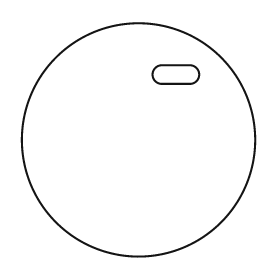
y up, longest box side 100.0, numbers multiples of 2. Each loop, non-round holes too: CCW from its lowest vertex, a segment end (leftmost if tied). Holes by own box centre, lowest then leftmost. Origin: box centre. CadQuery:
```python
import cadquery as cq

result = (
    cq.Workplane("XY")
    .moveTo(0.0, 0.0)
    .circle(50.0)
    .moveTo(10.0, 24.0)
    .lineTo(22.0, 24.0)
    .threePointArc((26.0, 28.0), (22.0, 32.0))
    .lineTo(10.0, 32.0)
    .threePointArc((6.0, 28.0), (10.0, 24.0))
    .close()
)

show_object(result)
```